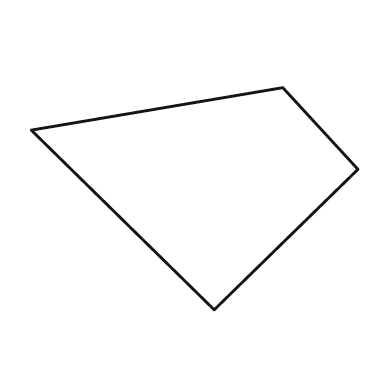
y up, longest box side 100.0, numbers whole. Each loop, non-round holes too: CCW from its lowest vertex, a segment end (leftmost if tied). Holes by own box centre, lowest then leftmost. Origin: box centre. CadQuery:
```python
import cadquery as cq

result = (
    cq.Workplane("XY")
    .moveTo(6.0, -34.0)
    .lineTo(50.0, 9.0)
    .lineTo(27.0, 34.0)
    .lineTo(-50.0, 21.0)
    .close()
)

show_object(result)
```